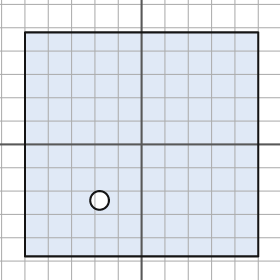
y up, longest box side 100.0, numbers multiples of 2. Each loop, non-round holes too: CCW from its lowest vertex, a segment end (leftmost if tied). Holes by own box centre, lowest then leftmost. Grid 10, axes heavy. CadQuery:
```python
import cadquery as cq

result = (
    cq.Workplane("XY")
    .moveTo(-50.0, -48.0)
    .lineTo(50.0, -48.0)
    .lineTo(50.0, 48.0)
    .lineTo(-50.0, 48.0)
    .close()
    .moveTo(-18.0, -24.0)
    .circle(4.0)
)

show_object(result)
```